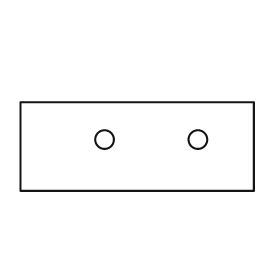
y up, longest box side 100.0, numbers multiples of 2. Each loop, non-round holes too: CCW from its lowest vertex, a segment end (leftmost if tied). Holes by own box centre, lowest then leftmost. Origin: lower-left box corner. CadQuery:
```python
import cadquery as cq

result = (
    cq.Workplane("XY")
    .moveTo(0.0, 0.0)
    .lineTo(100.0, 0.0)
    .lineTo(100.0, 38.0)
    .lineTo(0.0, 38.0)
    .close()
    .moveTo(36.0, 22.0)
    .circle(4.0)
    .moveTo(76.0, 22.0)
    .circle(4.0)
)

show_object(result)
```